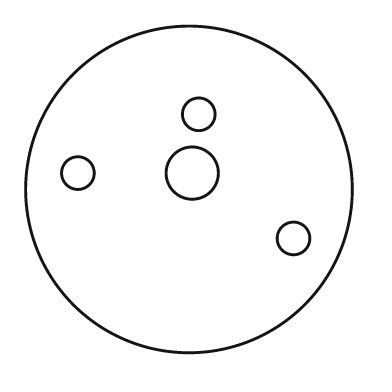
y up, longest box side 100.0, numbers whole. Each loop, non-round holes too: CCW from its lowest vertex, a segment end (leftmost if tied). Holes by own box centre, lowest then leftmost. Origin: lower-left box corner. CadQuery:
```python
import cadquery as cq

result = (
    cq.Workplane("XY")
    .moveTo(50.0, 50.0)
    .circle(50.0)
    .moveTo(82.0, 35.0)
    .circle(5.0)
    .moveTo(16.0, 55.0)
    .circle(5.0)
    .moveTo(51.0, 55.0)
    .circle(8.0)
    .moveTo(53.0, 73.0)
    .circle(5.0)
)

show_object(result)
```